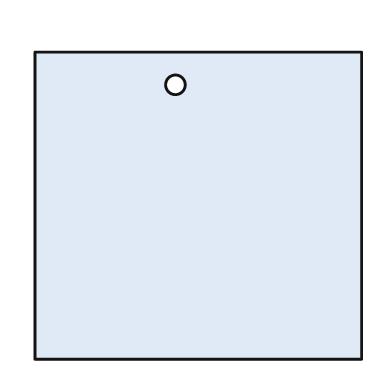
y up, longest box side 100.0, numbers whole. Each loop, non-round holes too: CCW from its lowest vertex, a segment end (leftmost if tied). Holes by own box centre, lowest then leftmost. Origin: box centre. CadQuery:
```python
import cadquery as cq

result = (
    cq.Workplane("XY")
    .moveTo(-50.0, -47.0)
    .lineTo(50.0, -47.0)
    .lineTo(50.0, 47.0)
    .lineTo(-50.0, 47.0)
    .close()
    .moveTo(-7.0, 37.0)
    .circle(3.0)
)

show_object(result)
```